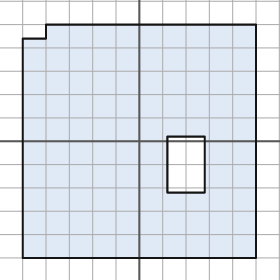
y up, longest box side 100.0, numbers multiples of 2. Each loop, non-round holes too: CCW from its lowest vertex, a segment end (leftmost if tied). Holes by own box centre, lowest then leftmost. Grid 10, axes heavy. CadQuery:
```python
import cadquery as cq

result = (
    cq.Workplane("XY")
    .moveTo(-50.0, -50.0)
    .lineTo(50.0, -50.0)
    .lineTo(50.0, 50.0)
    .lineTo(-40.0, 50.0)
    .lineTo(-40.0, 44.0)
    .lineTo(-50.0, 44.0)
    .close()
    .moveTo(12.0, -22.0)
    .lineTo(28.0, -22.0)
    .lineTo(28.0, 2.0)
    .lineTo(12.0, 2.0)
    .close()
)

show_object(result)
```